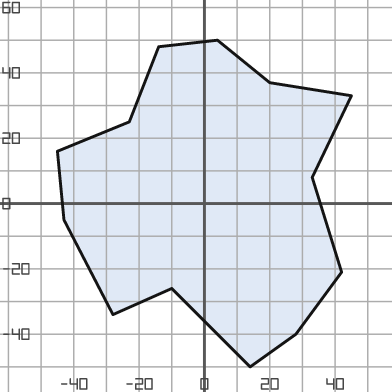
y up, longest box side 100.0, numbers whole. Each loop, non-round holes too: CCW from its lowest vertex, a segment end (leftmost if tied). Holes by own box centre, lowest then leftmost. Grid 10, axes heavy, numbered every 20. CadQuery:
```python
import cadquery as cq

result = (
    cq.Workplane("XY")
    .moveTo(14.0, -50.0)
    .lineTo(28.0, -40.0)
    .lineTo(42.0, -21.0)
    .lineTo(33.0, 8.0)
    .lineTo(45.0, 33.0)
    .lineTo(20.0, 37.0)
    .lineTo(4.0, 50.0)
    .lineTo(-14.0, 48.0)
    .lineTo(-23.0, 25.0)
    .lineTo(-45.0, 16.0)
    .lineTo(-43.0, -5.0)
    .lineTo(-28.0, -34.0)
    .lineTo(-10.0, -26.0)
    .close()
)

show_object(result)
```